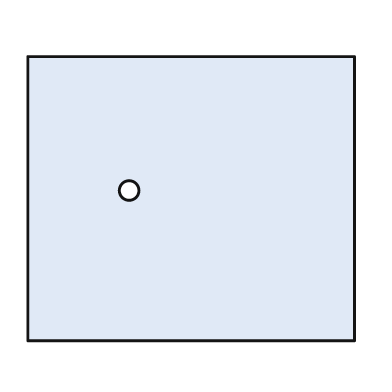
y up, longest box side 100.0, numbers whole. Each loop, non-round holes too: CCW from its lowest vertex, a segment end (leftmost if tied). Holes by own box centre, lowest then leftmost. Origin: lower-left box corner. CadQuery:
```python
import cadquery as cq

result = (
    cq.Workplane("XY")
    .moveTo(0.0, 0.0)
    .lineTo(100.0, 0.0)
    .lineTo(100.0, 87.0)
    .lineTo(0.0, 87.0)
    .close()
    .moveTo(31.0, 46.0)
    .circle(3.0)
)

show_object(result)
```